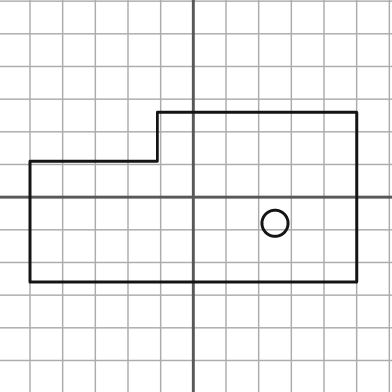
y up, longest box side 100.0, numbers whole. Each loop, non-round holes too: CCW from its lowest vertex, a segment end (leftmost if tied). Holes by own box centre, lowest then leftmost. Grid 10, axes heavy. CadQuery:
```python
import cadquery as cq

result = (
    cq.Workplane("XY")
    .moveTo(-50.0, -26.0)
    .lineTo(50.0, -26.0)
    .lineTo(50.0, 26.0)
    .lineTo(-11.0, 26.0)
    .lineTo(-11.0, 11.0)
    .lineTo(-50.0, 11.0)
    .close()
    .moveTo(25.0, -8.0)
    .circle(4.0)
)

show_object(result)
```